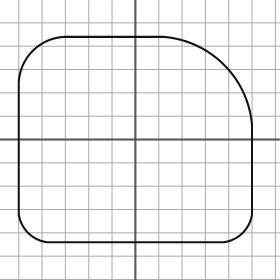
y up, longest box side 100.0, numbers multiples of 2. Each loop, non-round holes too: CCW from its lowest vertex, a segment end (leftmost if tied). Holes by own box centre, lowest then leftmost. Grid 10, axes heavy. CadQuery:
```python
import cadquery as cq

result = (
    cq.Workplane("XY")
    .moveTo(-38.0, -44.0)
    .lineTo(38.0, -44.0)
    .threePointArc((46.0, -40.0), (50.0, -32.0))
    .lineTo(50.0, 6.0)
    .threePointArc((38.0, 32.0), (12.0, 44.0))
    .lineTo(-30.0, 44.0)
    .threePointArc((-44.0, 38.0), (-50.0, 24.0))
    .lineTo(-50.0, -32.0)
    .threePointArc((-46.0, -40.0), (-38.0, -44.0))
    .close()
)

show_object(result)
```